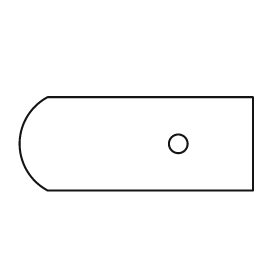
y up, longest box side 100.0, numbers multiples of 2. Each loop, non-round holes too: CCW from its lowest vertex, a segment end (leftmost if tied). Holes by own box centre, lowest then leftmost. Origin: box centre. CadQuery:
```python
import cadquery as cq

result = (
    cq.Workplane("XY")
    .moveTo(-38.0, -20.0)
    .lineTo(50.0, -20.0)
    .lineTo(50.0, 20.0)
    .lineTo(-38.0, 20.0)
    .threePointArc((-50.0, 0.0), (-38.0, -20.0))
    .close()
    .moveTo(18.0, 0.0)
    .circle(4.0)
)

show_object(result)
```